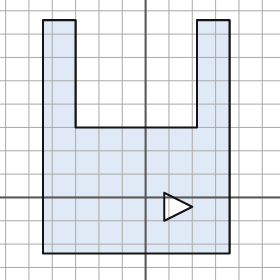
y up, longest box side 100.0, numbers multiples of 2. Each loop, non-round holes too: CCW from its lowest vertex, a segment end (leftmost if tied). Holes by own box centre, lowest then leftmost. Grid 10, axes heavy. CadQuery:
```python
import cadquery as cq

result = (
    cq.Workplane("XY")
    .moveTo(-44.0, -24.0)
    .lineTo(36.0, -24.0)
    .lineTo(36.0, 76.0)
    .lineTo(22.0, 76.0)
    .lineTo(22.0, 30.0)
    .lineTo(-30.0, 30.0)
    .lineTo(-30.0, 76.0)
    .lineTo(-44.0, 76.0)
    .close()
    .moveTo(8.0, -10.0)
    .lineTo(20.0, -4.0)
    .lineTo(8.0, 2.0)
    .close()
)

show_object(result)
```